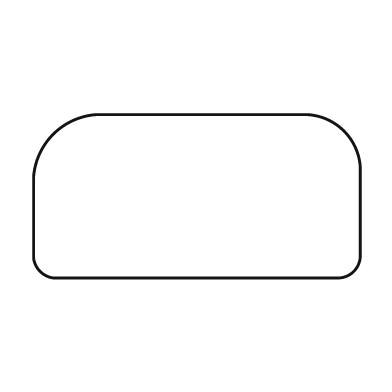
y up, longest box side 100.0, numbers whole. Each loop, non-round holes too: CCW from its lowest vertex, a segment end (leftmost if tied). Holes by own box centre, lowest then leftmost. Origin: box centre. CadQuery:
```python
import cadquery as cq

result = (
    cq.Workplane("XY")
    .moveTo(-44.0, -25.0)
    .lineTo(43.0, -25.0)
    .threePointArc((48.0, -23.0), (50.0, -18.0))
    .lineTo(50.0, 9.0)
    .threePointArc((45.0, 20.0), (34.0, 25.0))
    .lineTo(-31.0, 25.0)
    .threePointArc((-44.0, 19.0), (-50.0, 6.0))
    .lineTo(-50.0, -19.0)
    .threePointArc((-48.0, -23.0), (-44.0, -25.0))
    .close()
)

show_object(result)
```